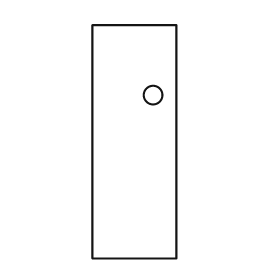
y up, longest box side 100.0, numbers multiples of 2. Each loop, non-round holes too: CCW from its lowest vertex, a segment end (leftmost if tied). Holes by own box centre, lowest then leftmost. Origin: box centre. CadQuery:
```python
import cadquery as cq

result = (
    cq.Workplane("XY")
    .moveTo(-18.0, -50.0)
    .lineTo(18.0, -50.0)
    .lineTo(18.0, 50.0)
    .lineTo(-18.0, 50.0)
    .close()
    .moveTo(8.0, 20.0)
    .circle(4.0)
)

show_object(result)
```